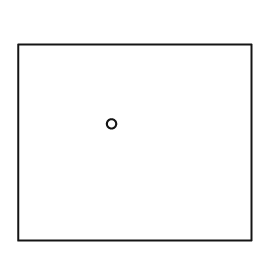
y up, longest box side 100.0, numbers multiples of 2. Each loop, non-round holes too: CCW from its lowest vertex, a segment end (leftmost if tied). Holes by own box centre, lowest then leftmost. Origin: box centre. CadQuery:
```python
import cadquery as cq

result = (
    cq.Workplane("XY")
    .moveTo(-50.0, -42.0)
    .lineTo(50.0, -42.0)
    .lineTo(50.0, 42.0)
    .lineTo(-50.0, 42.0)
    .close()
    .moveTo(-10.0, 8.0)
    .circle(2.0)
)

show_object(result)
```